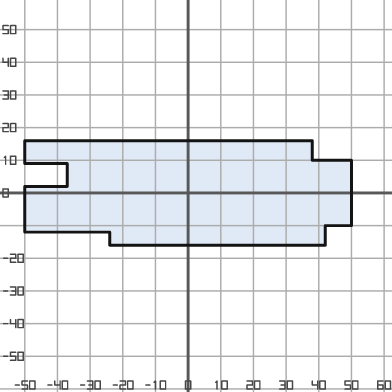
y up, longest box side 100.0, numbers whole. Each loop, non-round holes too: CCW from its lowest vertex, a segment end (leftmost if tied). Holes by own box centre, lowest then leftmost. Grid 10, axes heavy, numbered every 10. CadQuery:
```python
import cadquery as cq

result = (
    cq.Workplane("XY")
    .moveTo(-24.0, -16.0)
    .lineTo(42.0, -16.0)
    .lineTo(42.0, -10.0)
    .lineTo(50.0, -10.0)
    .lineTo(50.0, 10.0)
    .lineTo(38.0, 10.0)
    .lineTo(38.0, 16.0)
    .lineTo(-50.0, 16.0)
    .lineTo(-50.0, 9.0)
    .lineTo(-37.0, 9.0)
    .lineTo(-37.0, 2.0)
    .lineTo(-50.0, 2.0)
    .lineTo(-50.0, -12.0)
    .lineTo(-24.0, -12.0)
    .close()
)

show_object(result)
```